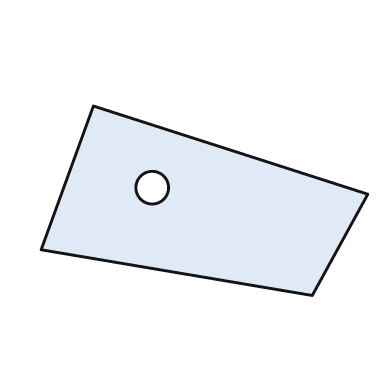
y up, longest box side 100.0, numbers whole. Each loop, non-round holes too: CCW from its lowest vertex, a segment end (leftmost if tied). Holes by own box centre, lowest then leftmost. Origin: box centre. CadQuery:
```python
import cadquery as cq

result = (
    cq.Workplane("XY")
    .moveTo(33.0, -29.0)
    .lineTo(50.0, 2.0)
    .lineTo(-34.0, 29.0)
    .lineTo(-50.0, -15.0)
    .close()
    .moveTo(-16.0, 4.0)
    .circle(5.0)
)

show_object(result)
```